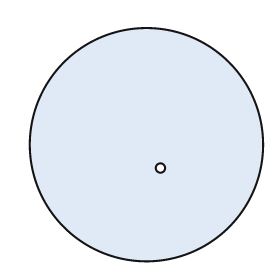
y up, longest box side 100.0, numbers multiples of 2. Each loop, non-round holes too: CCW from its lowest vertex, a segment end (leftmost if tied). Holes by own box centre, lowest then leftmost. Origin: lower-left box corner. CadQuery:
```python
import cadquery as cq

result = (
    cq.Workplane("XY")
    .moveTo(50.0, 50.0)
    .circle(50.0)
    .moveTo(56.0, 40.0)
    .circle(2.0)
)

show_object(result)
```